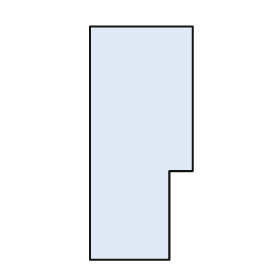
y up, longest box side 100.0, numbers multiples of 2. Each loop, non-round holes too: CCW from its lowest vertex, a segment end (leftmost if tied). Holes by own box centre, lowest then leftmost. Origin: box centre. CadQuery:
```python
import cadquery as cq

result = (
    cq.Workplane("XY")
    .moveTo(-22.0, -50.0)
    .lineTo(12.0, -50.0)
    .lineTo(12.0, -12.0)
    .lineTo(22.0, -12.0)
    .lineTo(22.0, 50.0)
    .lineTo(-22.0, 50.0)
    .close()
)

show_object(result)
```